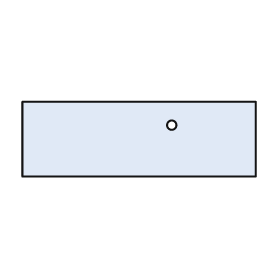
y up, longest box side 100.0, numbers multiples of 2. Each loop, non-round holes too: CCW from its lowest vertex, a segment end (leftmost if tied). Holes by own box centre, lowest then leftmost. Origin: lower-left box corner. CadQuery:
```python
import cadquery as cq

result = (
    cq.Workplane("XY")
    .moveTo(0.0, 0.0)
    .lineTo(100.0, 0.0)
    .lineTo(100.0, 32.0)
    .lineTo(0.0, 32.0)
    .close()
    .moveTo(64.0, 22.0)
    .circle(2.0)
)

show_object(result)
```